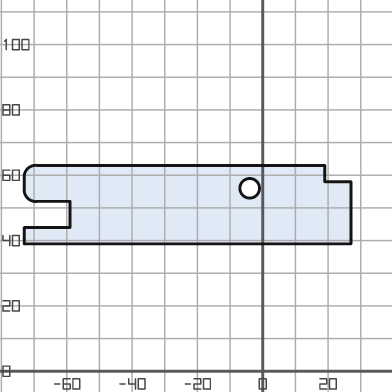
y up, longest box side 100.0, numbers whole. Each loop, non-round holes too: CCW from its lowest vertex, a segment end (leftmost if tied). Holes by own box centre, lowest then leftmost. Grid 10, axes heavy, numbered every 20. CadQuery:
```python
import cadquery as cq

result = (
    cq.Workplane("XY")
    .moveTo(-73.0, 39.0)
    .lineTo(27.0, 39.0)
    .lineTo(27.0, 58.0)
    .lineTo(19.0, 58.0)
    .lineTo(19.0, 63.0)
    .lineTo(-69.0, 63.0)
    .threePointArc((-72.0, 62.0), (-73.0, 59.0))
    .lineTo(-73.0, 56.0)
    .threePointArc((-72.0, 53.0), (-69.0, 52.0))
    .lineTo(-59.0, 52.0)
    .lineTo(-59.0, 44.0)
    .lineTo(-73.0, 44.0)
    .close()
    .moveTo(-4.0, 56.0)
    .circle(3.0)
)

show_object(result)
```